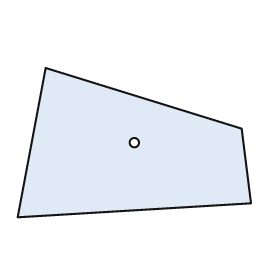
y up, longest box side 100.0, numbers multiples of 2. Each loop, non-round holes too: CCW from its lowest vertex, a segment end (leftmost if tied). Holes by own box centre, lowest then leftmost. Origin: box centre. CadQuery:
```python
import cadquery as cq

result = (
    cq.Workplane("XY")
    .moveTo(-50.0, -32.0)
    .lineTo(50.0, -26.0)
    .lineTo(46.0, 6.0)
    .lineTo(-38.0, 32.0)
    .close()
    .moveTo(0.0, 0.0)
    .circle(2.0)
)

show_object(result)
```